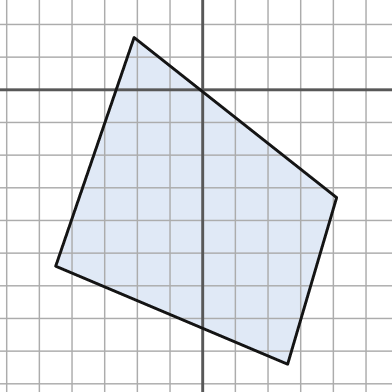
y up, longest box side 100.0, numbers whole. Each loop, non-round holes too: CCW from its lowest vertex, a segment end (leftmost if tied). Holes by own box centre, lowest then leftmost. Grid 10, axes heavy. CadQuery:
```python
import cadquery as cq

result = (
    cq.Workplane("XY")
    .moveTo(26.0, -84.0)
    .lineTo(41.0, -33.0)
    .lineTo(-21.0, 16.0)
    .lineTo(-45.0, -54.0)
    .close()
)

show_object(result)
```